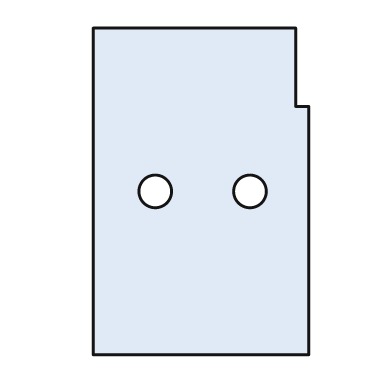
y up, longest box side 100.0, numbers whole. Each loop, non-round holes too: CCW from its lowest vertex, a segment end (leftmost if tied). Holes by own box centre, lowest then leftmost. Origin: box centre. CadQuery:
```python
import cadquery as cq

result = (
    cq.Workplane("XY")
    .moveTo(-33.0, -50.0)
    .lineTo(33.0, -50.0)
    .lineTo(33.0, 26.0)
    .lineTo(29.0, 26.0)
    .lineTo(29.0, 50.0)
    .lineTo(-33.0, 50.0)
    .close()
    .moveTo(-14.0, 0.0)
    .circle(5.0)
    .moveTo(15.0, 0.0)
    .circle(5.0)
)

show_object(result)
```